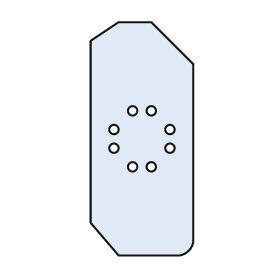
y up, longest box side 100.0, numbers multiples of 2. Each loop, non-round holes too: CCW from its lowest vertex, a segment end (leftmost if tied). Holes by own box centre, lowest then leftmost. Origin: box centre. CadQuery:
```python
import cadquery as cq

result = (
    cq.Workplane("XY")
    .moveTo(-10.0, -50.0)
    .lineTo(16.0, -50.0)
    .threePointArc((20.0, -48.0), (22.0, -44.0))
    .lineTo(22.0, 32.0)
    .lineTo(4.0, 50.0)
    .lineTo(-10.0, 50.0)
    .lineTo(-22.0, 42.0)
    .lineTo(-22.0, -36.0)
    .close()
    .moveTo(-4.0, -12.0)
    .circle(2.0)
    .moveTo(4.0, -12.0)
    .circle(2.0)
    .moveTo(-12.0, -4.0)
    .circle(2.0)
    .moveTo(12.0, -4.0)
    .circle(2.0)
    .moveTo(-12.0, 4.0)
    .circle(2.0)
    .moveTo(12.0, 4.0)
    .circle(2.0)
    .moveTo(-4.0, 12.0)
    .circle(2.0)
    .moveTo(4.0, 12.0)
    .circle(2.0)
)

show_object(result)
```